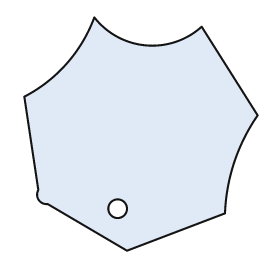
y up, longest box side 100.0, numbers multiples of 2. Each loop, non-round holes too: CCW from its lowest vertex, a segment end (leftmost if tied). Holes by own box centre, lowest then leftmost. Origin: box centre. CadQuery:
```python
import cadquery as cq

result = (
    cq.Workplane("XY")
    .moveTo(-6.0, -50.0)
    .lineTo(36.0, -34.0)
    .threePointArc((40.0, -12.0), (50.0, 8.0))
    .lineTo(26.0, 46.0)
    .threePointArc((2.0, 38.0), (-20.0, 50.0))
    .threePointArc((-32.0, 30.0), (-50.0, 16.0))
    .lineTo(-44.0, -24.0)
    .threePointArc((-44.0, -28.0), (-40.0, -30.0))
    .close()
    .moveTo(-10.0, -32.0)
    .circle(4.0)
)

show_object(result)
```